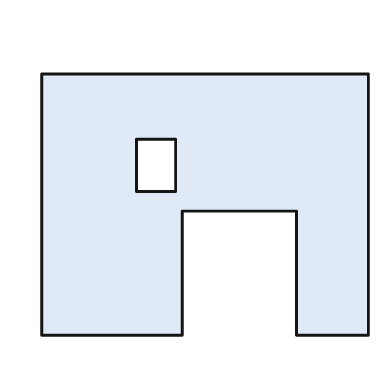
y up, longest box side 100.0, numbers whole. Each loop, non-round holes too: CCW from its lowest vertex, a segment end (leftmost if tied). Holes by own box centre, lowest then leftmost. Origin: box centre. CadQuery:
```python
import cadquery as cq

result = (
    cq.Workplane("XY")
    .moveTo(-50.0, -40.0)
    .lineTo(-7.0, -40.0)
    .lineTo(-7.0, -2.0)
    .lineTo(28.0, -2.0)
    .lineTo(28.0, -40.0)
    .lineTo(50.0, -40.0)
    .lineTo(50.0, 40.0)
    .lineTo(-50.0, 40.0)
    .close()
    .moveTo(-21.0, 4.0)
    .lineTo(-9.0, 4.0)
    .lineTo(-9.0, 20.0)
    .lineTo(-21.0, 20.0)
    .close()
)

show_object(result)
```